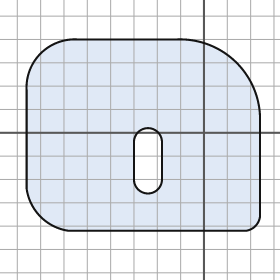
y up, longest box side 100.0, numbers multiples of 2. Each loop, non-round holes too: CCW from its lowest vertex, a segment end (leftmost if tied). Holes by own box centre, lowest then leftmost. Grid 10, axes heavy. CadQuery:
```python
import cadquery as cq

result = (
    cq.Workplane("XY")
    .moveTo(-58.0, -42.0)
    .lineTo(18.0, -42.0)
    .threePointArc((22.0, -40.0), (24.0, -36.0))
    .lineTo(24.0, 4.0)
    .threePointArc((14.0, 30.0), (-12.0, 40.0))
    .lineTo(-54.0, 40.0)
    .threePointArc((-70.0, 34.0), (-76.0, 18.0))
    .lineTo(-76.0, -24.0)
    .threePointArc((-70.0, -36.0), (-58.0, -42.0))
    .close()
    .moveTo(-30.0, -20.0)
    .threePointArc((-24.0, -26.0), (-18.0, -20.0))
    .lineTo(-18.0, -4.0)
    .threePointArc((-24.0, 2.0), (-30.0, -4.0))
    .close()
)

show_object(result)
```